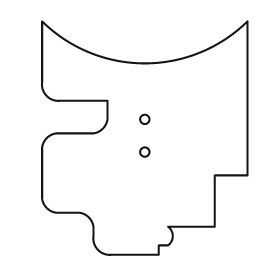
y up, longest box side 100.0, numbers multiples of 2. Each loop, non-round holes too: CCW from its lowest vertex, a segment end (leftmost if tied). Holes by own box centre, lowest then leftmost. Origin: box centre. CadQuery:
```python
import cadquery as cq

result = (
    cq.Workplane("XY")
    .moveTo(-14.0, -50.0)
    .lineTo(6.0, -50.0)
    .lineTo(6.0, -46.0)
    .lineTo(10.0, -46.0)
    .threePointArc((12.0, -42.0), (10.0, -38.0))
    .lineTo(30.0, -38.0)
    .lineTo(30.0, -16.0)
    .lineTo(44.0, -16.0)
    .lineTo(44.0, 50.0)
    .threePointArc((0.0, 32.0), (-44.0, 50.0))
    .lineTo(-44.0, 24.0)
    .threePointArc((-42.0, 18.0), (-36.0, 16.0))
    .lineTo(-16.0, 16.0)
    .lineTo(-16.0, 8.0)
    .threePointArc((-18.0, 4.0), (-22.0, 2.0))
    .lineTo(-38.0, 2.0)
    .threePointArc((-42.0, 0.0), (-44.0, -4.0))
    .lineTo(-44.0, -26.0)
    .threePointArc((-42.0, -30.0), (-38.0, -32.0))
    .lineTo(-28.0, -32.0)
    .threePointArc((-24.0, -34.0), (-22.0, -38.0))
    .lineTo(-22.0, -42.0)
    .threePointArc((-20.0, -48.0), (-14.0, -50.0))
    .close()
    .moveTo(0.0, -6.0)
    .circle(2.0)
    .moveTo(0.0, 8.0)
    .circle(2.0)
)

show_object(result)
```